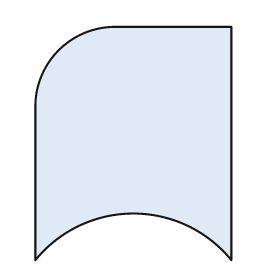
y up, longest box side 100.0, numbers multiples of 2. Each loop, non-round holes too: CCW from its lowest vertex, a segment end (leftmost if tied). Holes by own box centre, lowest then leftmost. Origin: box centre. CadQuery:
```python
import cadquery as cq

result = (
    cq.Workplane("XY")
    .moveTo(-42.0, -50.0)
    .threePointArc((0.0, -30.0), (42.0, -50.0))
    .lineTo(42.0, 50.0)
    .lineTo(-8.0, 50.0)
    .threePointArc((-32.0, 40.0), (-42.0, 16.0))
    .close()
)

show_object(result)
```